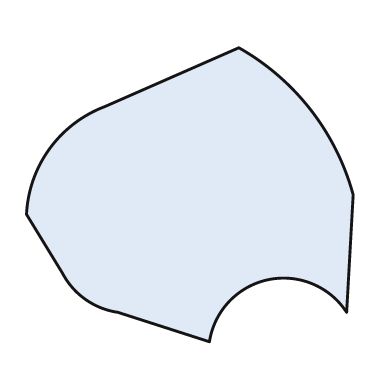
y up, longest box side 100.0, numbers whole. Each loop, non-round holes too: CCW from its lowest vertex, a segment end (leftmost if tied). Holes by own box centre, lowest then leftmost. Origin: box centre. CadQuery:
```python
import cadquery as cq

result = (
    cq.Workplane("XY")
    .moveTo(6.0, -45.0)
    .threePointArc((24.0, -26.0), (48.0, -36.0))
    .lineTo(50.0, 0.0)
    .threePointArc((37.0, 26.0), (15.0, 45.0))
    .lineTo(-26.0, 27.0)
    .threePointArc((-43.0, 14.0), (-50.0, -6.0))
    .lineTo(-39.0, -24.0)
    .threePointArc((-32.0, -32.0), (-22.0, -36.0))
    .close()
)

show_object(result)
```